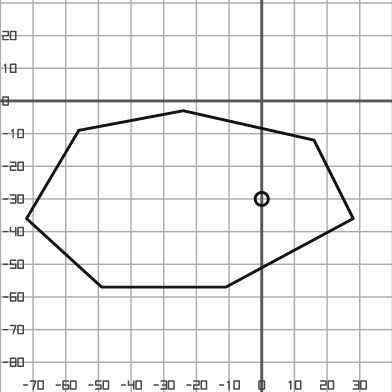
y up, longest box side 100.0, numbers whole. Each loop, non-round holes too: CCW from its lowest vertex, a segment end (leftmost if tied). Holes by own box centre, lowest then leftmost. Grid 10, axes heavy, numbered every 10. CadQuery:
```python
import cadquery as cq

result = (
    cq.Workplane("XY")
    .moveTo(-49.0, -57.0)
    .lineTo(-11.0, -57.0)
    .lineTo(28.0, -36.0)
    .lineTo(16.0, -12.0)
    .lineTo(-24.0, -3.0)
    .lineTo(-56.0, -9.0)
    .lineTo(-72.0, -36.0)
    .close()
    .moveTo(0.0, -30.0)
    .circle(2.0)
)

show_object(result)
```